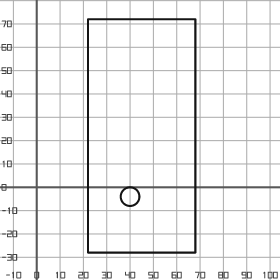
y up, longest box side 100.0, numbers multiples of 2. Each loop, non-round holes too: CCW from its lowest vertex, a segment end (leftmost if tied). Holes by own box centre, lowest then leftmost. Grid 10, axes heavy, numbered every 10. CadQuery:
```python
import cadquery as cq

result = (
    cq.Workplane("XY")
    .moveTo(22.0, -28.0)
    .lineTo(68.0, -28.0)
    .lineTo(68.0, 72.0)
    .lineTo(22.0, 72.0)
    .close()
    .moveTo(40.0, -4.0)
    .circle(4.0)
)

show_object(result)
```